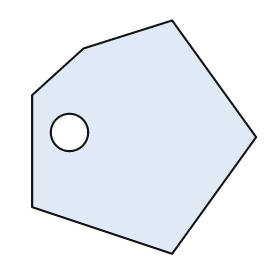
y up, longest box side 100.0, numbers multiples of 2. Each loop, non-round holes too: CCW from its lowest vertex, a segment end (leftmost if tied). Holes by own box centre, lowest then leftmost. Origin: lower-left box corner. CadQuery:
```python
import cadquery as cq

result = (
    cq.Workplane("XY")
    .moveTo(60.0, 0.0)
    .lineTo(96.0, 50.0)
    .lineTo(60.0, 100.0)
    .lineTo(22.0, 88.0)
    .lineTo(0.0, 68.0)
    .lineTo(0.0, 20.0)
    .close()
    .moveTo(16.0, 52.0)
    .circle(8.0)
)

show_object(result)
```